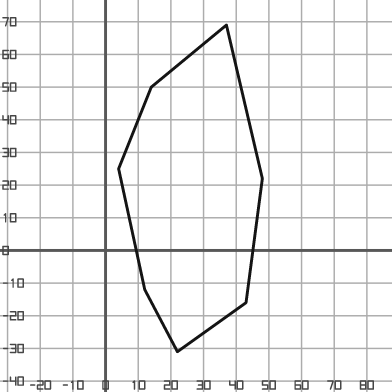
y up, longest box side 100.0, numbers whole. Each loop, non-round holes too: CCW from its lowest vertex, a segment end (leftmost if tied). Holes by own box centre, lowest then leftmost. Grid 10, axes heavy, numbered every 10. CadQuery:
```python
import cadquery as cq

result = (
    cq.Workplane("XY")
    .moveTo(22.0, -31.0)
    .lineTo(43.0, -16.0)
    .lineTo(48.0, 22.0)
    .lineTo(37.0, 69.0)
    .lineTo(14.0, 50.0)
    .lineTo(4.0, 25.0)
    .lineTo(12.0, -12.0)
    .close()
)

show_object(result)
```